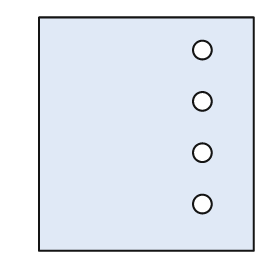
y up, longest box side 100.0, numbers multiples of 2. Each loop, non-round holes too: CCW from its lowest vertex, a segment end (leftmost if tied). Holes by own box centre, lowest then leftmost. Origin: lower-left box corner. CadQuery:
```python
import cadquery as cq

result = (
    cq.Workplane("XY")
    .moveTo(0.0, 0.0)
    .lineTo(92.0, 0.0)
    .lineTo(92.0, 100.0)
    .lineTo(0.0, 100.0)
    .close()
    .moveTo(70.0, 20.0)
    .circle(4.0)
    .moveTo(70.0, 42.0)
    .circle(4.0)
    .moveTo(70.0, 64.0)
    .circle(4.0)
    .moveTo(70.0, 86.0)
    .circle(4.0)
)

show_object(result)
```